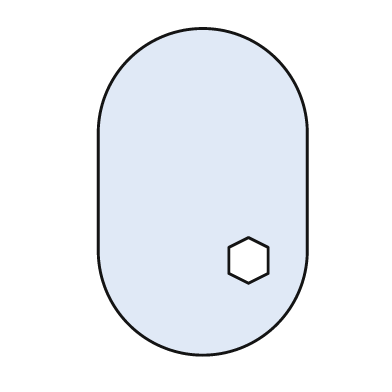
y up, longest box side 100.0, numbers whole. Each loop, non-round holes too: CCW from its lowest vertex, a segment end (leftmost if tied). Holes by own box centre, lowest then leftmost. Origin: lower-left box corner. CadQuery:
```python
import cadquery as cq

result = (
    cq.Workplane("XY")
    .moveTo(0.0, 32.0)
    .threePointArc((32.0, 0.0), (64.0, 32.0))
    .lineTo(64.0, 68.0)
    .threePointArc((32.0, 100.0), (0.0, 68.0))
    .close()
    .moveTo(46.0, 22.0)
    .lineTo(52.0, 25.0)
    .lineTo(52.0, 33.0)
    .lineTo(46.0, 36.0)
    .lineTo(40.0, 33.0)
    .lineTo(40.0, 25.0)
    .close()
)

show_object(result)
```